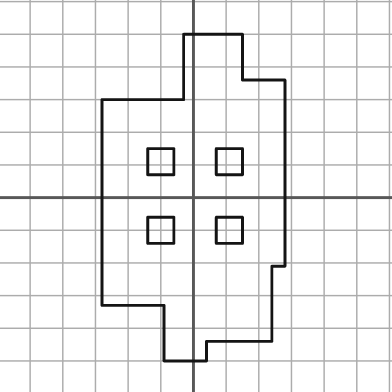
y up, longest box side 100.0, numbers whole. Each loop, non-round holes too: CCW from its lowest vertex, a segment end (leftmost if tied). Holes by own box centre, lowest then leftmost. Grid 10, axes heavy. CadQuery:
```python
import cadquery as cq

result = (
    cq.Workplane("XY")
    .moveTo(-9.0, -50.0)
    .lineTo(4.0, -50.0)
    .lineTo(4.0, -44.0)
    .lineTo(24.0, -44.0)
    .lineTo(24.0, -21.0)
    .lineTo(28.0, -21.0)
    .lineTo(28.0, 36.0)
    .lineTo(15.0, 36.0)
    .lineTo(15.0, 50.0)
    .lineTo(-3.0, 50.0)
    .lineTo(-3.0, 30.0)
    .lineTo(-28.0, 30.0)
    .lineTo(-28.0, -33.0)
    .lineTo(-9.0, -33.0)
    .close()
    .moveTo(-14.0, -14.0)
    .lineTo(-6.0, -14.0)
    .lineTo(-6.0, -6.0)
    .lineTo(-14.0, -6.0)
    .close()
    .moveTo(7.0, -14.0)
    .lineTo(15.0, -14.0)
    .lineTo(15.0, -6.0)
    .lineTo(7.0, -6.0)
    .close()
    .moveTo(-14.0, 7.0)
    .lineTo(-6.0, 7.0)
    .lineTo(-6.0, 15.0)
    .lineTo(-14.0, 15.0)
    .close()
    .moveTo(7.0, 7.0)
    .lineTo(15.0, 7.0)
    .lineTo(15.0, 15.0)
    .lineTo(7.0, 15.0)
    .close()
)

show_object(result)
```